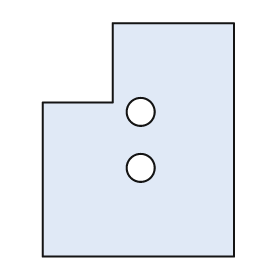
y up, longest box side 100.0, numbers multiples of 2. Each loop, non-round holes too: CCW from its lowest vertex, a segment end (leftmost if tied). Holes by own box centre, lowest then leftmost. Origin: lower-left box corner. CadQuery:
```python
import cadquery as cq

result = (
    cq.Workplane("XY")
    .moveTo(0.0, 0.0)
    .lineTo(82.0, 0.0)
    .lineTo(82.0, 100.0)
    .lineTo(30.0, 100.0)
    .lineTo(30.0, 66.0)
    .lineTo(0.0, 66.0)
    .close()
    .moveTo(42.0, 38.0)
    .circle(6.0)
    .moveTo(42.0, 62.0)
    .circle(6.0)
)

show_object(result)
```